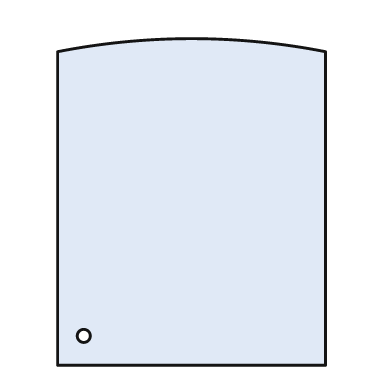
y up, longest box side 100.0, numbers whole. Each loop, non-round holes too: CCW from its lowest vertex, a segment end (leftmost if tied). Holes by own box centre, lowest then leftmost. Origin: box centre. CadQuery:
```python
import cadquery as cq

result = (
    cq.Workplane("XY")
    .moveTo(-41.0, -50.0)
    .lineTo(41.0, -50.0)
    .lineTo(41.0, 46.0)
    .threePointArc((0.0, 50.0), (-41.0, 46.0))
    .close()
    .moveTo(-33.0, -41.0)
    .circle(2.0)
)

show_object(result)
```